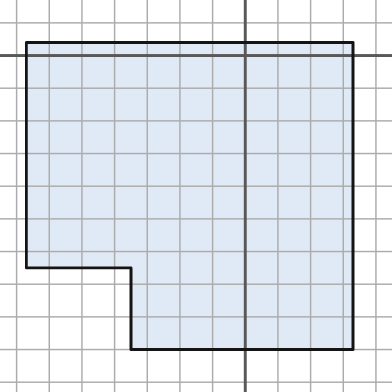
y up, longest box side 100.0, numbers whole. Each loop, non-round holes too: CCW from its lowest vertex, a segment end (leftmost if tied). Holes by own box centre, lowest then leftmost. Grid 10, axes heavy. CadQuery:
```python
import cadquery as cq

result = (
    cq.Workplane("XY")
    .moveTo(-35.0, -90.0)
    .lineTo(33.0, -90.0)
    .lineTo(33.0, 4.0)
    .lineTo(-67.0, 4.0)
    .lineTo(-67.0, -65.0)
    .lineTo(-35.0, -65.0)
    .close()
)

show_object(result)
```